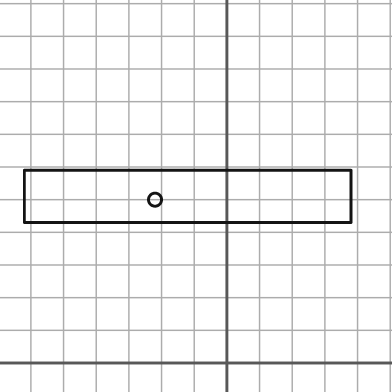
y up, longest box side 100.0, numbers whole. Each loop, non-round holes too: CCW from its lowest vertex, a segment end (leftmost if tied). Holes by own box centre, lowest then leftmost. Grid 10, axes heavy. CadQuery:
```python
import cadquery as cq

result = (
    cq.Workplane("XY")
    .moveTo(-62.0, 43.0)
    .lineTo(38.0, 43.0)
    .lineTo(38.0, 59.0)
    .lineTo(-62.0, 59.0)
    .close()
    .moveTo(-22.0, 50.0)
    .circle(2.0)
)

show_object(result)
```